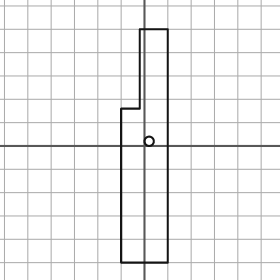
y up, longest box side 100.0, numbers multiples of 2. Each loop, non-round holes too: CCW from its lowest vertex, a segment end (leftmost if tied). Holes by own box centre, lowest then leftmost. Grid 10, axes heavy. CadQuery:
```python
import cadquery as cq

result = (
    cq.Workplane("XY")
    .moveTo(-10.0, -50.0)
    .lineTo(10.0, -50.0)
    .lineTo(10.0, 50.0)
    .lineTo(-2.0, 50.0)
    .lineTo(-2.0, 16.0)
    .lineTo(-10.0, 16.0)
    .close()
    .moveTo(2.0, 2.0)
    .circle(2.0)
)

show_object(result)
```